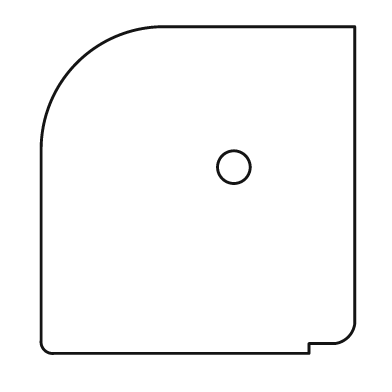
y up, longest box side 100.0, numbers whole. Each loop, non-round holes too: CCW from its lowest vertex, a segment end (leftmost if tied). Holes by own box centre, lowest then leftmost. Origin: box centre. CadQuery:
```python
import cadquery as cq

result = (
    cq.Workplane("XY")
    .moveTo(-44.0, -50.0)
    .lineTo(34.0, -50.0)
    .lineTo(34.0, -47.0)
    .lineTo(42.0, -47.0)
    .threePointArc((46.0, -45.0), (48.0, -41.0))
    .lineTo(48.0, 50.0)
    .lineTo(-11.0, 50.0)
    .threePointArc((-37.0, 39.0), (-48.0, 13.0))
    .lineTo(-48.0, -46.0)
    .threePointArc((-47.0, -49.0), (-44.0, -50.0))
    .close()
    .moveTo(11.0, 7.0)
    .circle(5.0)
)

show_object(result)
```